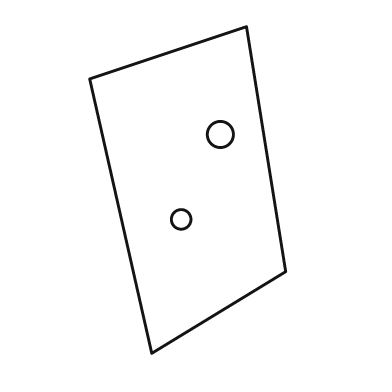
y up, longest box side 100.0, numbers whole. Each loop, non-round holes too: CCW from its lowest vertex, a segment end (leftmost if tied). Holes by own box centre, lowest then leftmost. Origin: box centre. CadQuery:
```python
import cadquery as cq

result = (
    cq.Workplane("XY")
    .moveTo(-11.0, -50.0)
    .lineTo(30.0, -25.0)
    .lineTo(18.0, 50.0)
    .lineTo(-30.0, 34.0)
    .close()
    .moveTo(-2.0, -9.0)
    .circle(3.0)
    .moveTo(10.0, 17.0)
    .circle(4.0)
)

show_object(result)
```